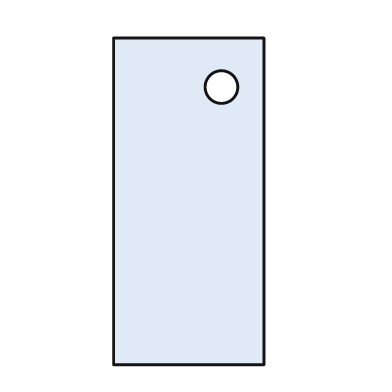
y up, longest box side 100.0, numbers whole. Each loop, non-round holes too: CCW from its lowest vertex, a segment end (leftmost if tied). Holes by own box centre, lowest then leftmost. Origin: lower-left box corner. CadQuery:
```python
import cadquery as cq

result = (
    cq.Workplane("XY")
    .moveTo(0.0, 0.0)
    .lineTo(46.0, 0.0)
    .lineTo(46.0, 100.0)
    .lineTo(0.0, 100.0)
    .close()
    .moveTo(33.0, 85.0)
    .circle(5.0)
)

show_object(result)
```